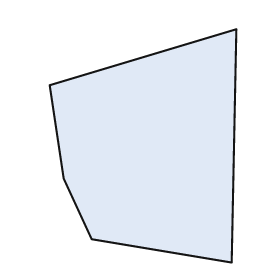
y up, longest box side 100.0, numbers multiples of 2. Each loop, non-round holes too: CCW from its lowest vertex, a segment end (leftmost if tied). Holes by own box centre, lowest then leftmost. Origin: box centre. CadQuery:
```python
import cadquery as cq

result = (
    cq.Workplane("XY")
    .moveTo(38.0, -50.0)
    .lineTo(40.0, 50.0)
    .lineTo(-40.0, 26.0)
    .lineTo(-34.0, -14.0)
    .lineTo(-22.0, -40.0)
    .close()
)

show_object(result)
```